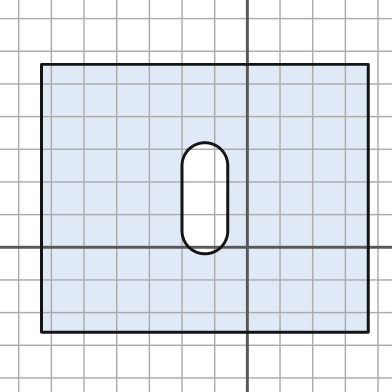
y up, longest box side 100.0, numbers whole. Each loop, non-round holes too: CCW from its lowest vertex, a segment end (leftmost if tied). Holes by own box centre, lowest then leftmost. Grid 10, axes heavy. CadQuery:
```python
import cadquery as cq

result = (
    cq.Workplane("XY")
    .moveTo(-63.0, -26.0)
    .lineTo(37.0, -26.0)
    .lineTo(37.0, 56.0)
    .lineTo(-63.0, 56.0)
    .close()
    .moveTo(-20.0, 5.0)
    .threePointArc((-13.0, -2.0), (-6.0, 5.0))
    .lineTo(-6.0, 25.0)
    .threePointArc((-13.0, 32.0), (-20.0, 25.0))
    .close()
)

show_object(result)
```